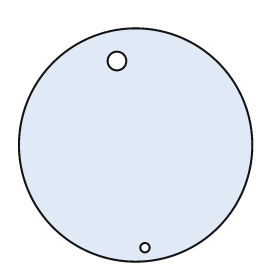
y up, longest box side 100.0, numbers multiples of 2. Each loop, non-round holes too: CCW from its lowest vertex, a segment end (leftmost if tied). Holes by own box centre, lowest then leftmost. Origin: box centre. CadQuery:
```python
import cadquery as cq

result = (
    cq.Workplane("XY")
    .moveTo(0.0, 0.0)
    .circle(50.0)
    .moveTo(4.0, -44.0)
    .circle(2.0)
    .moveTo(-8.0, 36.0)
    .circle(4.0)
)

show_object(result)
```